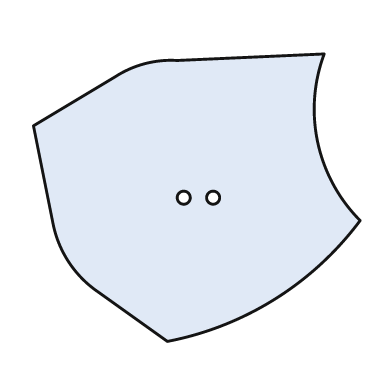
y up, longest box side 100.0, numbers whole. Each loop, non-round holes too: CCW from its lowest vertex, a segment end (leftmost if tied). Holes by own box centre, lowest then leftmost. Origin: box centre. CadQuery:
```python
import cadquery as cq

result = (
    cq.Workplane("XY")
    .moveTo(-9.0, -44.0)
    .threePointArc((24.0, -31.0), (50.0, -7.0))
    .threePointArc((37.0, 17.0), (39.0, 44.0))
    .lineTo(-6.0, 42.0)
    .threePointArc((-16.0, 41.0), (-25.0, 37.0))
    .lineTo(-50.0, 22.0)
    .lineTo(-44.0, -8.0)
    .threePointArc((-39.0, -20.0), (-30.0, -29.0))
    .close()
    .moveTo(-4.0, 0.0)
    .circle(2.0)
    .moveTo(5.0, 0.0)
    .circle(2.0)
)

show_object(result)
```